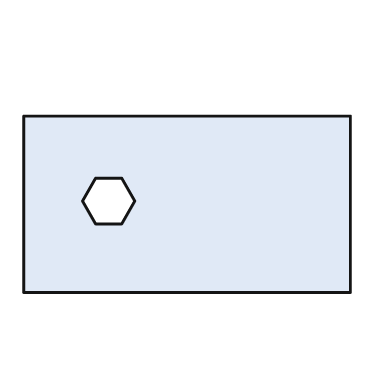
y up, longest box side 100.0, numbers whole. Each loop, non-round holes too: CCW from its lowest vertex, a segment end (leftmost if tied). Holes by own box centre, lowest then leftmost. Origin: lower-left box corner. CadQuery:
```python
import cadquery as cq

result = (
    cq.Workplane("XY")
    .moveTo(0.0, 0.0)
    .lineTo(100.0, 0.0)
    .lineTo(100.0, 54.0)
    .lineTo(0.0, 54.0)
    .close()
    .moveTo(22.0, 21.0)
    .lineTo(30.0, 21.0)
    .lineTo(34.0, 28.0)
    .lineTo(30.0, 35.0)
    .lineTo(22.0, 35.0)
    .lineTo(18.0, 28.0)
    .close()
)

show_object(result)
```